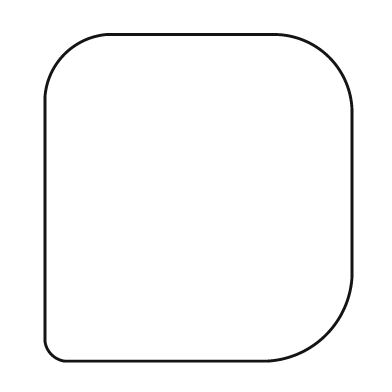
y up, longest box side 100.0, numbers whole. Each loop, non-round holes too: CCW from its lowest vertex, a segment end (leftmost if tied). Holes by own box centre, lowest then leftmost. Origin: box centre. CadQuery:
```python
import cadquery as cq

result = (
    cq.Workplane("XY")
    .moveTo(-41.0, -50.0)
    .lineTo(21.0, -50.0)
    .threePointArc((39.0, -42.0), (47.0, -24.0))
    .lineTo(47.0, 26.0)
    .threePointArc((40.0, 43.0), (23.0, 50.0))
    .lineTo(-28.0, 50.0)
    .threePointArc((-41.0, 44.0), (-47.0, 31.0))
    .lineTo(-47.0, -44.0)
    .threePointArc((-45.0, -48.0), (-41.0, -50.0))
    .close()
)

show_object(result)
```